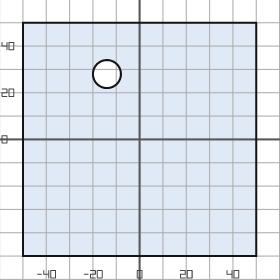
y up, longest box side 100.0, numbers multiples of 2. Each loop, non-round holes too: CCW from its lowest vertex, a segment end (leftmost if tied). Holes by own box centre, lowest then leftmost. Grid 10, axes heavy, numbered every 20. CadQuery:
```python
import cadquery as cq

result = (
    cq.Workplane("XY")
    .moveTo(-50.0, -50.0)
    .lineTo(50.0, -50.0)
    .lineTo(50.0, 50.0)
    .lineTo(-50.0, 50.0)
    .close()
    .moveTo(-14.0, 28.0)
    .circle(6.0)
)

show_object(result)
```